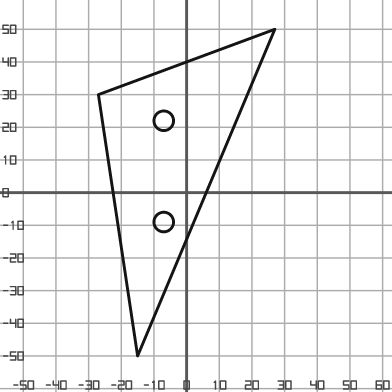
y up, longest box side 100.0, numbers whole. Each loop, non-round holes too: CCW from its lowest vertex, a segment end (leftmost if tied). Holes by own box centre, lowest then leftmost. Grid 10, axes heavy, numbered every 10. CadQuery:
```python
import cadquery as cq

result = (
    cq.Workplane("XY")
    .moveTo(-15.0, -50.0)
    .lineTo(27.0, 50.0)
    .lineTo(-27.0, 30.0)
    .close()
    .moveTo(-7.0, -9.0)
    .circle(3.0)
    .moveTo(-7.0, 22.0)
    .circle(3.0)
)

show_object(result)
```